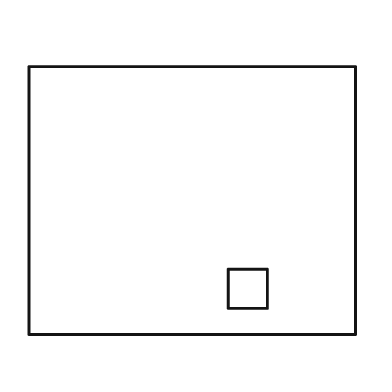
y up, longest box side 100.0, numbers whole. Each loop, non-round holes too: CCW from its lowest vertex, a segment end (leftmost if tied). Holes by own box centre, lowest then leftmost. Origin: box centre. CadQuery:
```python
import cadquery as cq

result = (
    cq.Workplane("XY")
    .moveTo(-50.0, -41.0)
    .lineTo(50.0, -41.0)
    .lineTo(50.0, 41.0)
    .lineTo(-50.0, 41.0)
    .close()
    .moveTo(11.0, -33.0)
    .lineTo(23.0, -33.0)
    .lineTo(23.0, -21.0)
    .lineTo(11.0, -21.0)
    .close()
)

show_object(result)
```